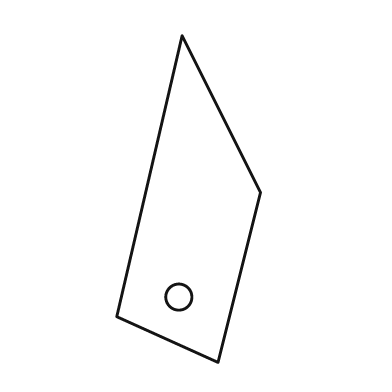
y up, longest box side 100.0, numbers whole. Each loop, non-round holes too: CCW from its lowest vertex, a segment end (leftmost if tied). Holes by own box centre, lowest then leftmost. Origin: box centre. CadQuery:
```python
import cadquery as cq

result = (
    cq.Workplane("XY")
    .moveTo(9.0, -50.0)
    .lineTo(22.0, 2.0)
    .lineTo(-2.0, 50.0)
    .lineTo(-22.0, -36.0)
    .close()
    .moveTo(-3.0, -30.0)
    .circle(4.0)
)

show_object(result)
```